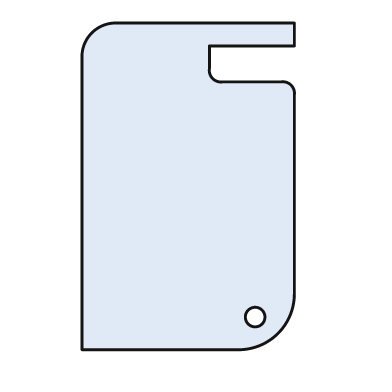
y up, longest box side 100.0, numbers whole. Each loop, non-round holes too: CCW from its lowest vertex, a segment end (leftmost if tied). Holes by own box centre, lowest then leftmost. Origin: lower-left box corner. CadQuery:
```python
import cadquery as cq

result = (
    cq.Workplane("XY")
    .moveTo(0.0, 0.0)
    .lineTo(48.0, 0.0)
    .threePointArc((60.0, 5.0), (65.0, 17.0))
    .lineTo(65.0, 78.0)
    .threePointArc((64.0, 81.0), (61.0, 82.0))
    .lineTo(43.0, 82.0)
    .threePointArc((40.0, 83.0), (39.0, 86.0))
    .lineTo(39.0, 93.0)
    .lineTo(65.0, 93.0)
    .lineTo(65.0, 100.0)
    .lineTo(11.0, 100.0)
    .threePointArc((3.0, 97.0), (0.0, 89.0))
    .close()
    .moveTo(53.0, 10.0)
    .circle(3.0)
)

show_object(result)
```